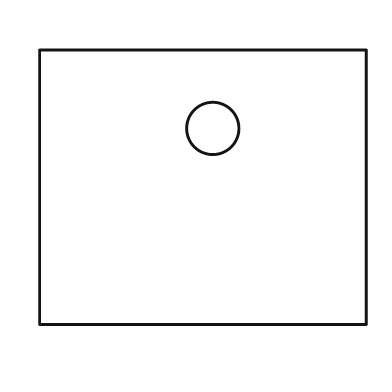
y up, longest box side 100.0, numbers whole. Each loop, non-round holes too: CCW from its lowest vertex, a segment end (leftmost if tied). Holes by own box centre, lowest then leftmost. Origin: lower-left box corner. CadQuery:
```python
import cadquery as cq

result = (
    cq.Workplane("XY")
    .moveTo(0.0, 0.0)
    .lineTo(100.0, 0.0)
    .lineTo(100.0, 84.0)
    .lineTo(0.0, 84.0)
    .close()
    .moveTo(53.0, 60.0)
    .circle(8.0)
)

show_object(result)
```